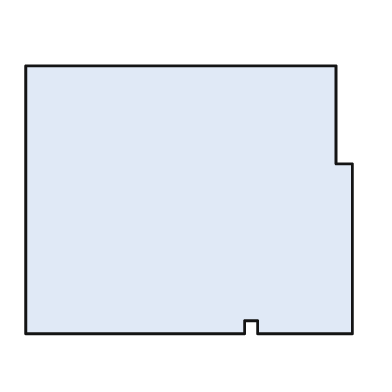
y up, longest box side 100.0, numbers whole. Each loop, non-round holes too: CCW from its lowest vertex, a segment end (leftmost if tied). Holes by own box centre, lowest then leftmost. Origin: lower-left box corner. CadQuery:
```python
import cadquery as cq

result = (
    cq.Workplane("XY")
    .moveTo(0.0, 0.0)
    .lineTo(67.0, 0.0)
    .lineTo(67.0, 4.0)
    .lineTo(71.0, 4.0)
    .lineTo(71.0, 0.0)
    .lineTo(100.0, 0.0)
    .lineTo(100.0, 52.0)
    .lineTo(95.0, 52.0)
    .lineTo(95.0, 82.0)
    .lineTo(0.0, 82.0)
    .close()
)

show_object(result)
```